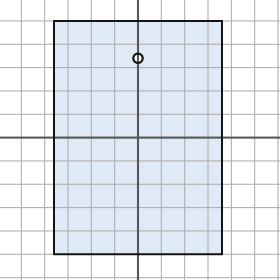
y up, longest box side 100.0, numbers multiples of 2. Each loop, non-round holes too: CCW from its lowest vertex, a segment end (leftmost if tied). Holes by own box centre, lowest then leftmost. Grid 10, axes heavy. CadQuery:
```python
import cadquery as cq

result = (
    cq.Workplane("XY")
    .moveTo(-36.0, -50.0)
    .lineTo(36.0, -50.0)
    .lineTo(36.0, 50.0)
    .lineTo(-36.0, 50.0)
    .close()
    .moveTo(0.0, 34.0)
    .circle(2.0)
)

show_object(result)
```